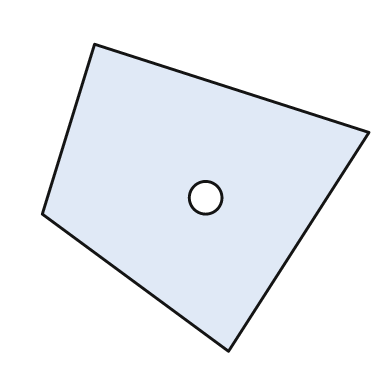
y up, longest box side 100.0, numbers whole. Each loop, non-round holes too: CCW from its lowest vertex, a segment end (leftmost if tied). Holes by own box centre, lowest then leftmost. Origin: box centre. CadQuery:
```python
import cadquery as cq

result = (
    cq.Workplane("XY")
    .moveTo(7.0, -47.0)
    .lineTo(50.0, 20.0)
    .lineTo(-34.0, 47.0)
    .lineTo(-50.0, -5.0)
    .close()
    .moveTo(0.0, 0.0)
    .circle(5.0)
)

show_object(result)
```